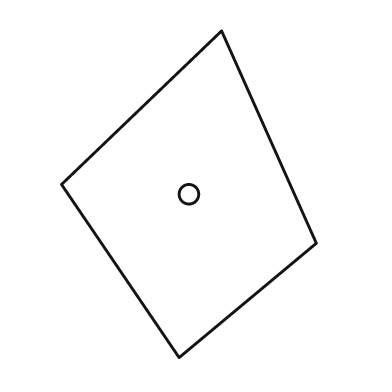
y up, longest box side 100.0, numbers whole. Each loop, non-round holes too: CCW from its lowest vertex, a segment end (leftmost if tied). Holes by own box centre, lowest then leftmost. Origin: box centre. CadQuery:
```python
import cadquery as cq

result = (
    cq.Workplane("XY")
    .moveTo(-3.0, -50.0)
    .lineTo(39.0, -15.0)
    .lineTo(10.0, 50.0)
    .lineTo(-39.0, 3.0)
    .close()
    .moveTo(0.0, 0.0)
    .circle(3.0)
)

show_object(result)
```